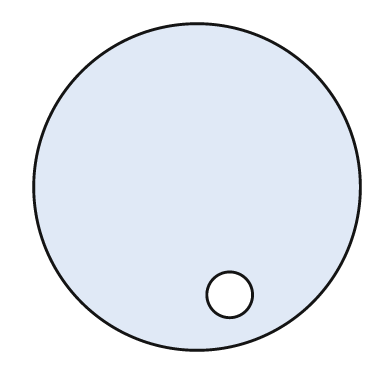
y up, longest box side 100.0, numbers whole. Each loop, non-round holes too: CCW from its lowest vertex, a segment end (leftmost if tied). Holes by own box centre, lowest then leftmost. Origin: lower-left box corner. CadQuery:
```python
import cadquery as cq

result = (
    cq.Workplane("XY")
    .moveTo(50.0, 50.0)
    .circle(50.0)
    .moveTo(60.0, 17.0)
    .circle(7.0)
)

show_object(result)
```